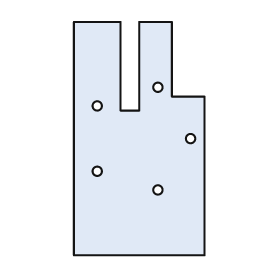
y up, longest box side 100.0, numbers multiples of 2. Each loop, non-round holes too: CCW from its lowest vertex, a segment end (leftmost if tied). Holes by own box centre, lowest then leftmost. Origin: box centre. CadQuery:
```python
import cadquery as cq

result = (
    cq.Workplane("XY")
    .moveTo(-28.0, -50.0)
    .lineTo(28.0, -50.0)
    .lineTo(28.0, 18.0)
    .lineTo(14.0, 18.0)
    .lineTo(14.0, 50.0)
    .lineTo(0.0, 50.0)
    .lineTo(0.0, 12.0)
    .lineTo(-8.0, 12.0)
    .lineTo(-8.0, 50.0)
    .lineTo(-28.0, 50.0)
    .close()
    .moveTo(8.0, -22.0)
    .circle(2.0)
    .moveTo(-18.0, -14.0)
    .circle(2.0)
    .moveTo(22.0, 0.0)
    .circle(2.0)
    .moveTo(-18.0, 14.0)
    .circle(2.0)
    .moveTo(8.0, 22.0)
    .circle(2.0)
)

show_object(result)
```